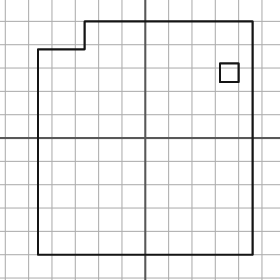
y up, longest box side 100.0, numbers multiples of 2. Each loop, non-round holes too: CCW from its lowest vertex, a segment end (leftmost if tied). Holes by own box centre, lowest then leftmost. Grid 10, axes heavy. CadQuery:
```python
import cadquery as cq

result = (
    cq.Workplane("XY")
    .moveTo(-46.0, -50.0)
    .lineTo(46.0, -50.0)
    .lineTo(46.0, 50.0)
    .lineTo(-26.0, 50.0)
    .lineTo(-26.0, 38.0)
    .lineTo(-46.0, 38.0)
    .close()
    .moveTo(32.0, 24.0)
    .lineTo(40.0, 24.0)
    .lineTo(40.0, 32.0)
    .lineTo(32.0, 32.0)
    .close()
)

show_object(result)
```